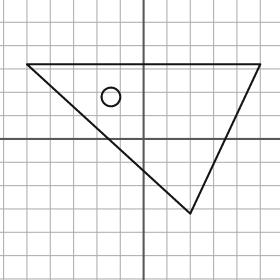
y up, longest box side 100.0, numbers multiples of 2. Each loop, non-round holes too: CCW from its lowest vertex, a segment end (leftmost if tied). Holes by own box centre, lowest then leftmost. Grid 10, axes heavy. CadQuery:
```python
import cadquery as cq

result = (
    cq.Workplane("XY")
    .moveTo(20.0, -32.0)
    .lineTo(50.0, 32.0)
    .lineTo(-50.0, 32.0)
    .close()
    .moveTo(-14.0, 18.0)
    .circle(4.0)
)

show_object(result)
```